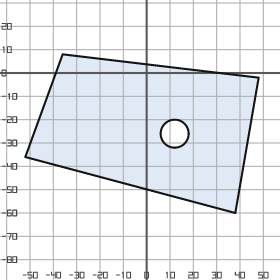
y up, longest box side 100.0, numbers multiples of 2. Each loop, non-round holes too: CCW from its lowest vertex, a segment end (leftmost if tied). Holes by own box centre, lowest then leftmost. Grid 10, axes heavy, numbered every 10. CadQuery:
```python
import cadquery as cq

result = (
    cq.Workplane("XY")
    .moveTo(38.0, -60.0)
    .lineTo(48.0, -2.0)
    .lineTo(-36.0, 8.0)
    .lineTo(-52.0, -36.0)
    .close()
    .moveTo(12.0, -26.0)
    .circle(6.0)
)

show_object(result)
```